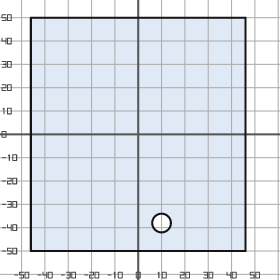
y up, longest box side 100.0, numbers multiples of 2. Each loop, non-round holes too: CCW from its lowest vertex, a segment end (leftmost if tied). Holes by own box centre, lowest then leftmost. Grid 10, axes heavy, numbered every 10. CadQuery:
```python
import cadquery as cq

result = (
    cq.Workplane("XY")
    .moveTo(-46.0, -50.0)
    .lineTo(46.0, -50.0)
    .lineTo(46.0, 50.0)
    .lineTo(-46.0, 50.0)
    .close()
    .moveTo(10.0, -38.0)
    .circle(4.0)
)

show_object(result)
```